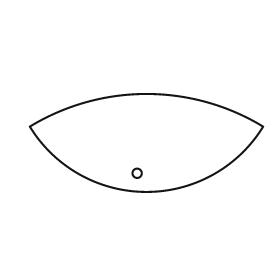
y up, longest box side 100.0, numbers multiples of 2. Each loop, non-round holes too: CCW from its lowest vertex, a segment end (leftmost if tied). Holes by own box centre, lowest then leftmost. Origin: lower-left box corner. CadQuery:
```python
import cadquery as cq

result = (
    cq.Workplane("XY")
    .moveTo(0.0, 28.0)
    .threePointArc((50.0, 0.0), (100.0, 28.0))
    .threePointArc((50.0, 42.0), (0.0, 28.0))
    .close()
    .moveTo(46.0, 8.0)
    .circle(2.0)
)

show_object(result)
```